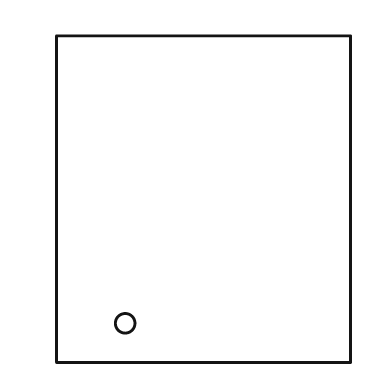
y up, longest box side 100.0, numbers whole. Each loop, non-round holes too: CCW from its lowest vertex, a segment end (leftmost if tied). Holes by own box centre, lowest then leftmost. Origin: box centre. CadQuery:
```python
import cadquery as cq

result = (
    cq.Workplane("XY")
    .moveTo(-45.0, -50.0)
    .lineTo(45.0, -50.0)
    .lineTo(45.0, 50.0)
    .lineTo(-45.0, 50.0)
    .close()
    .moveTo(-24.0, -38.0)
    .circle(3.0)
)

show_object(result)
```